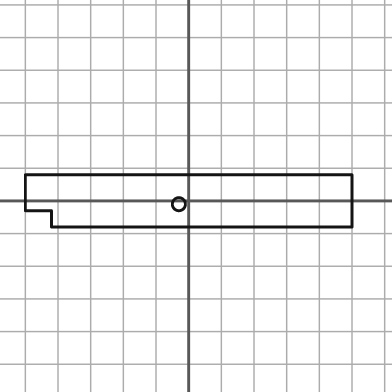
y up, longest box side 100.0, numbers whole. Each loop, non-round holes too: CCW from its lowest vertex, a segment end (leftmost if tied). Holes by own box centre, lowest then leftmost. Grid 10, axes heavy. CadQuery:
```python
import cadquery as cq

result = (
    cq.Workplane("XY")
    .moveTo(-42.0, -8.0)
    .lineTo(50.0, -8.0)
    .lineTo(50.0, 8.0)
    .lineTo(-50.0, 8.0)
    .lineTo(-50.0, -3.0)
    .lineTo(-42.0, -3.0)
    .close()
    .moveTo(-3.0, -1.0)
    .circle(2.0)
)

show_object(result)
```